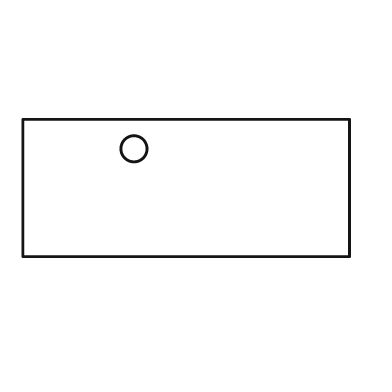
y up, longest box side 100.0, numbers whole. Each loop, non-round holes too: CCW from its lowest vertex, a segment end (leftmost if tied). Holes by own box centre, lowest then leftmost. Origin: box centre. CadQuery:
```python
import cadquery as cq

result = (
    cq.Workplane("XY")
    .moveTo(-50.0, -21.0)
    .lineTo(50.0, -21.0)
    .lineTo(50.0, 21.0)
    .lineTo(-50.0, 21.0)
    .close()
    .moveTo(-16.0, 12.0)
    .circle(4.0)
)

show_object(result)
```